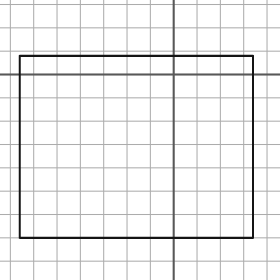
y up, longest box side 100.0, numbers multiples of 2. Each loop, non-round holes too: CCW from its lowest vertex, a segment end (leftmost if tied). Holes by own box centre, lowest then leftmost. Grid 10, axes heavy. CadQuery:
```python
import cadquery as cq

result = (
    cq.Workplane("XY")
    .moveTo(-66.0, -70.0)
    .lineTo(34.0, -70.0)
    .lineTo(34.0, 8.0)
    .lineTo(-66.0, 8.0)
    .close()
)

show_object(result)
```